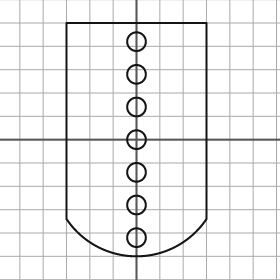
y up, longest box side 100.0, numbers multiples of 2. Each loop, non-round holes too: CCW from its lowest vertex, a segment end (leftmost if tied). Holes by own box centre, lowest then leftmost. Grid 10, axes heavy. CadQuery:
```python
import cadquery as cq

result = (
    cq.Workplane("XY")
    .moveTo(-30.0, -34.0)
    .threePointArc((0.0, -50.0), (30.0, -34.0))
    .lineTo(30.0, 50.0)
    .lineTo(-30.0, 50.0)
    .close()
    .moveTo(0.0, -42.0)
    .circle(4.0)
    .moveTo(0.0, -28.0)
    .circle(4.0)
    .moveTo(0.0, -14.0)
    .circle(4.0)
    .moveTo(0.0, 0.0)
    .circle(4.0)
    .moveTo(0.0, 14.0)
    .circle(4.0)
    .moveTo(0.0, 28.0)
    .circle(4.0)
    .moveTo(0.0, 42.0)
    .circle(4.0)
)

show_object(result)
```